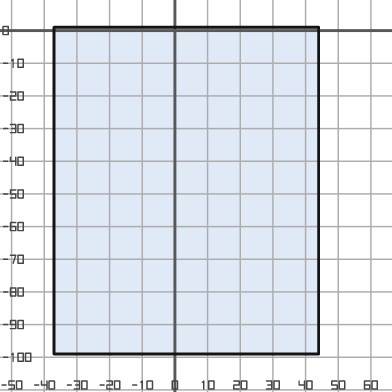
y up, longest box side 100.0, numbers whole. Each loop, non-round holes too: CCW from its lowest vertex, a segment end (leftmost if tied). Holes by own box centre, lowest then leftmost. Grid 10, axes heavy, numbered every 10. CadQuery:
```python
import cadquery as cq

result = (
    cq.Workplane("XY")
    .moveTo(-37.0, -99.0)
    .lineTo(44.0, -99.0)
    .lineTo(44.0, 1.0)
    .lineTo(-37.0, 1.0)
    .close()
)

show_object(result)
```